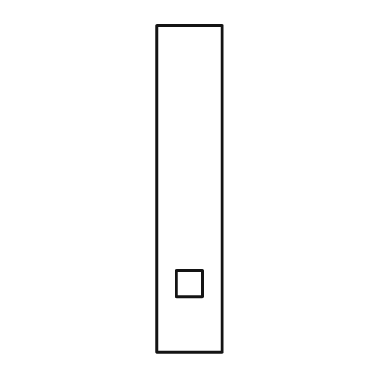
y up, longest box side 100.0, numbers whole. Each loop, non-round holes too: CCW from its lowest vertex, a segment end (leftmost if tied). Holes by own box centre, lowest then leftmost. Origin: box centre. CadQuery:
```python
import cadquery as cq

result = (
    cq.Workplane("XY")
    .moveTo(-10.0, -50.0)
    .lineTo(10.0, -50.0)
    .lineTo(10.0, 50.0)
    .lineTo(-10.0, 50.0)
    .close()
    .moveTo(-4.0, -33.0)
    .lineTo(4.0, -33.0)
    .lineTo(4.0, -25.0)
    .lineTo(-4.0, -25.0)
    .close()
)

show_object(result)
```